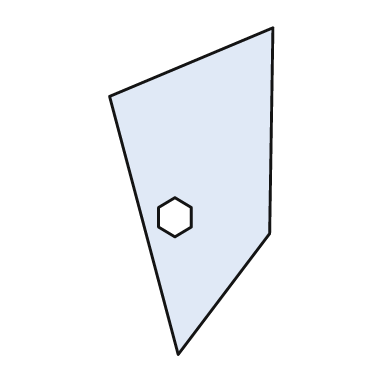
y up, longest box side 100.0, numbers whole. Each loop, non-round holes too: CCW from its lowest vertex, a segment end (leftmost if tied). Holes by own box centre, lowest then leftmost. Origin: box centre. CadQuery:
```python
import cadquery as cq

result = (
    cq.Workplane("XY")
    .moveTo(-4.0, -50.0)
    .lineTo(24.0, -13.0)
    .lineTo(25.0, 50.0)
    .lineTo(-25.0, 29.0)
    .close()
    .moveTo(-5.0, -14.0)
    .lineTo(0.0, -11.0)
    .lineTo(0.0, -5.0)
    .lineTo(-5.0, -2.0)
    .lineTo(-10.0, -5.0)
    .lineTo(-10.0, -11.0)
    .close()
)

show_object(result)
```